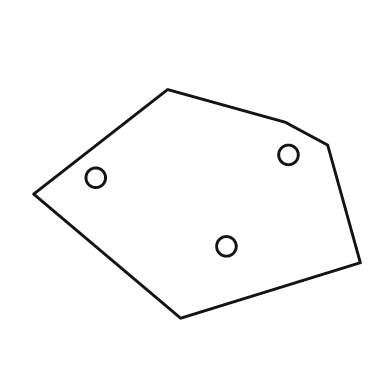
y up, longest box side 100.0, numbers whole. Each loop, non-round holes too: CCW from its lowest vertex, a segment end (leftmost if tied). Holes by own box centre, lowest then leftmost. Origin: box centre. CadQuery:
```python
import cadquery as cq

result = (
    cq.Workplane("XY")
    .moveTo(-5.0, -35.0)
    .lineTo(50.0, -18.0)
    .lineTo(40.0, 18.0)
    .lineTo(27.0, 25.0)
    .lineTo(-9.0, 35.0)
    .lineTo(-50.0, 3.0)
    .close()
    .moveTo(9.0, -13.0)
    .circle(3.0)
    .moveTo(-31.0, 8.0)
    .circle(3.0)
    .moveTo(28.0, 15.0)
    .circle(3.0)
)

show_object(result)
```